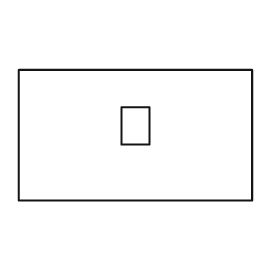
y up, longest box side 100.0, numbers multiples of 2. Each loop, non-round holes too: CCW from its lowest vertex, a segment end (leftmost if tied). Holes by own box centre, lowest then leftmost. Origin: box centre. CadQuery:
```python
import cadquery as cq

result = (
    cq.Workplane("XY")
    .moveTo(-50.0, -28.0)
    .lineTo(50.0, -28.0)
    .lineTo(50.0, 28.0)
    .lineTo(-50.0, 28.0)
    .close()
    .moveTo(-6.0, -4.0)
    .lineTo(6.0, -4.0)
    .lineTo(6.0, 12.0)
    .lineTo(-6.0, 12.0)
    .close()
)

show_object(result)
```